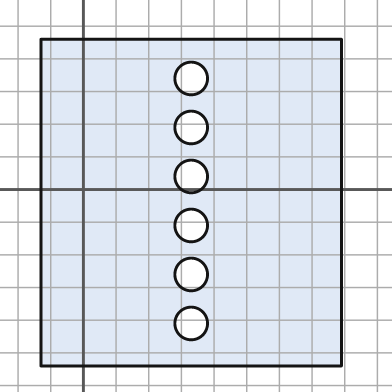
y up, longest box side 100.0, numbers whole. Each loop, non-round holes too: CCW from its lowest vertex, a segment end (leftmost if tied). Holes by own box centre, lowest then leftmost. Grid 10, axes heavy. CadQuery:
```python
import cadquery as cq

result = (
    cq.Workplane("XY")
    .moveTo(-13.0, -54.0)
    .lineTo(79.0, -54.0)
    .lineTo(79.0, 46.0)
    .lineTo(-13.0, 46.0)
    .close()
    .moveTo(33.0, -41.0)
    .circle(5.0)
    .moveTo(33.0, -26.0)
    .circle(5.0)
    .moveTo(33.0, -11.0)
    .circle(5.0)
    .moveTo(33.0, 4.0)
    .circle(5.0)
    .moveTo(33.0, 19.0)
    .circle(5.0)
    .moveTo(33.0, 34.0)
    .circle(5.0)
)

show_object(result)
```